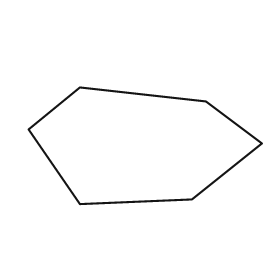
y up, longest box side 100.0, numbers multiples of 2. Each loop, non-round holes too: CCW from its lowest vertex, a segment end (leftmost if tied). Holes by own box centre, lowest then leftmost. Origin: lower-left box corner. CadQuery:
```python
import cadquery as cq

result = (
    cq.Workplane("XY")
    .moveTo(22.0, 0.0)
    .lineTo(70.0, 2.0)
    .lineTo(100.0, 26.0)
    .lineTo(76.0, 44.0)
    .lineTo(22.0, 50.0)
    .lineTo(0.0, 32.0)
    .close()
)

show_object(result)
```